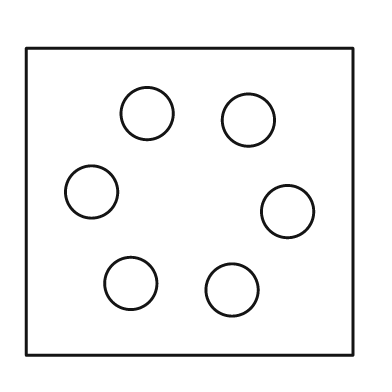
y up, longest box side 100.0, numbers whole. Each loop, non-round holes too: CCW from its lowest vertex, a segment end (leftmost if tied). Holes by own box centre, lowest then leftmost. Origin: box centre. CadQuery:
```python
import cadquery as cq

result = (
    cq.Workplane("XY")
    .moveTo(-50.0, -47.0)
    .lineTo(50.0, -47.0)
    .lineTo(50.0, 47.0)
    .lineTo(-50.0, 47.0)
    .close()
    .moveTo(13.0, -27.0)
    .circle(8.0)
    .moveTo(-18.0, -25.0)
    .circle(8.0)
    .moveTo(30.0, -3.0)
    .circle(8.0)
    .moveTo(-30.0, 3.0)
    .circle(8.0)
    .moveTo(18.0, 25.0)
    .circle(8.0)
    .moveTo(-13.0, 27.0)
    .circle(8.0)
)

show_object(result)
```